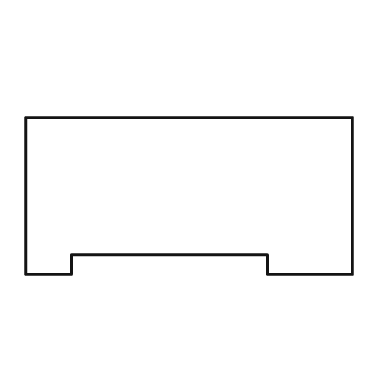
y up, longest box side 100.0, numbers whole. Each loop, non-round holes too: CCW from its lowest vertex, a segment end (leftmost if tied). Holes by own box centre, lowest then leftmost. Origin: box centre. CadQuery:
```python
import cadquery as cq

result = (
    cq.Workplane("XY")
    .moveTo(-50.0, -24.0)
    .lineTo(-36.0, -24.0)
    .lineTo(-36.0, -18.0)
    .lineTo(24.0, -18.0)
    .lineTo(24.0, -24.0)
    .lineTo(50.0, -24.0)
    .lineTo(50.0, 24.0)
    .lineTo(-50.0, 24.0)
    .close()
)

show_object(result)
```